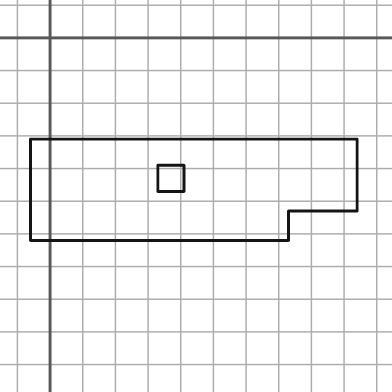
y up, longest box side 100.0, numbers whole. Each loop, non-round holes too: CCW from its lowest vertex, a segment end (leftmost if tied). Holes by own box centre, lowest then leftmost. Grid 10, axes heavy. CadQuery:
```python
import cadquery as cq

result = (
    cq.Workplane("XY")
    .moveTo(-6.0, -62.0)
    .lineTo(73.0, -62.0)
    .lineTo(73.0, -53.0)
    .lineTo(94.0, -53.0)
    .lineTo(94.0, -31.0)
    .lineTo(-6.0, -31.0)
    .close()
    .moveTo(33.0, -47.0)
    .lineTo(41.0, -47.0)
    .lineTo(41.0, -39.0)
    .lineTo(33.0, -39.0)
    .close()
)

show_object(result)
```